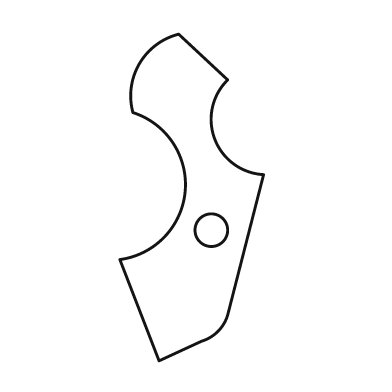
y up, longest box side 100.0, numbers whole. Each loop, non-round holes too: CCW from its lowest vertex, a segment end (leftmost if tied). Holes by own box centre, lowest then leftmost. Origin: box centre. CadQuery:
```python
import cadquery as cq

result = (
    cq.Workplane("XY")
    .moveTo(-10.0, -50.0)
    .lineTo(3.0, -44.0)
    .threePointArc((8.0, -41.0), (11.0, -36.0))
    .lineTo(22.0, 7.0)
    .threePointArc((7.0, 18.0), (11.0, 36.0))
    .lineTo(-4.0, 50.0)
    .threePointArc((-16.0, 41.0), (-18.0, 26.0))
    .threePointArc((-2.0, 2.0), (-22.0, -19.0))
    .close()
    .moveTo(6.0, -10.0)
    .circle(5.0)
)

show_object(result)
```